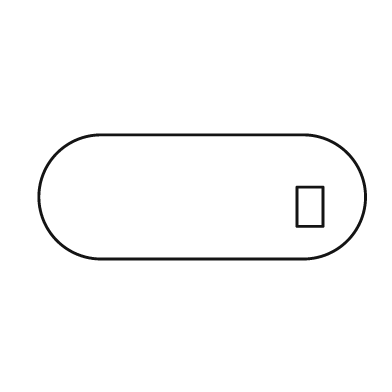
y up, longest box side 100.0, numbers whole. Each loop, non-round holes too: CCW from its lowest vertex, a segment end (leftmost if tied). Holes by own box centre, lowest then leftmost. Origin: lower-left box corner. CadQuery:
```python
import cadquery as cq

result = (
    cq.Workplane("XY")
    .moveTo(19.0, 0.0)
    .lineTo(81.0, 0.0)
    .threePointArc((100.0, 19.0), (81.0, 38.0))
    .lineTo(19.0, 38.0)
    .threePointArc((0.0, 19.0), (19.0, 0.0))
    .close()
    .moveTo(79.0, 10.0)
    .lineTo(87.0, 10.0)
    .lineTo(87.0, 22.0)
    .lineTo(79.0, 22.0)
    .close()
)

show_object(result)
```